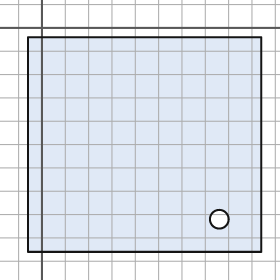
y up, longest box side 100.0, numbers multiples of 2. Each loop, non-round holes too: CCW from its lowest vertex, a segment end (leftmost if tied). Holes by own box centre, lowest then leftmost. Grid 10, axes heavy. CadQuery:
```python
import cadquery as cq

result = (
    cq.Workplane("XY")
    .moveTo(-6.0, -96.0)
    .lineTo(94.0, -96.0)
    .lineTo(94.0, -4.0)
    .lineTo(-6.0, -4.0)
    .close()
    .moveTo(76.0, -82.0)
    .circle(4.0)
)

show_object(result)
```